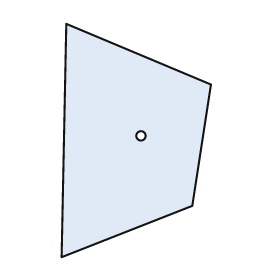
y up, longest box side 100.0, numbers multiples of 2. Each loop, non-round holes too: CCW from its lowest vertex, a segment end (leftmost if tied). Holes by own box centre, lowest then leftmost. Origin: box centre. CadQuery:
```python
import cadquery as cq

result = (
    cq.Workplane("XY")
    .moveTo(-32.0, -50.0)
    .lineTo(24.0, -28.0)
    .lineTo(32.0, 24.0)
    .lineTo(-30.0, 50.0)
    .close()
    .moveTo(2.0, 2.0)
    .circle(2.0)
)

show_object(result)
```